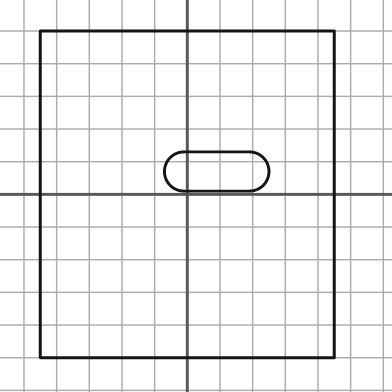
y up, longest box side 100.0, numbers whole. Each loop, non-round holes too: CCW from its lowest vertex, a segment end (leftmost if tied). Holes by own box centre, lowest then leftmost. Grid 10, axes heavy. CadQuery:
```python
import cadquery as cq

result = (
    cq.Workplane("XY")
    .moveTo(-45.0, -50.0)
    .lineTo(45.0, -50.0)
    .lineTo(45.0, 50.0)
    .lineTo(-45.0, 50.0)
    .close()
    .moveTo(-1.0, 1.0)
    .lineTo(19.0, 1.0)
    .threePointArc((25.0, 7.0), (19.0, 13.0))
    .lineTo(-1.0, 13.0)
    .threePointArc((-7.0, 7.0), (-1.0, 1.0))
    .close()
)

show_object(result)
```